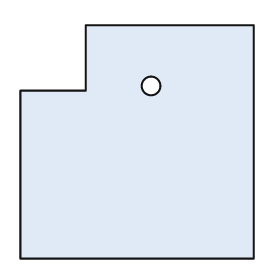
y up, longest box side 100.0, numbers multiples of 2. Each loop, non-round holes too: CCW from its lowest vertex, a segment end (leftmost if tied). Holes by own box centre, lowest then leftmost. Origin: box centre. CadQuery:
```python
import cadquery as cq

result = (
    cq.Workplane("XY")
    .moveTo(-50.0, -50.0)
    .lineTo(50.0, -50.0)
    .lineTo(50.0, 50.0)
    .lineTo(-22.0, 50.0)
    .lineTo(-22.0, 22.0)
    .lineTo(-50.0, 22.0)
    .close()
    .moveTo(6.0, 24.0)
    .circle(4.0)
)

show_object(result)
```